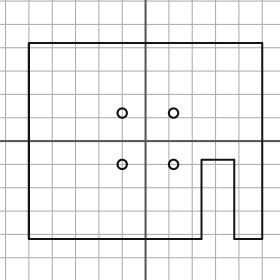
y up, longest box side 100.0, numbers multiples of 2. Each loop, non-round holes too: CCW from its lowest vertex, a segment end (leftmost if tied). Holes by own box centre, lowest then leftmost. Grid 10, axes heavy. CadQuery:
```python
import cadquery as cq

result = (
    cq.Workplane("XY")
    .moveTo(-50.0, -42.0)
    .lineTo(24.0, -42.0)
    .lineTo(24.0, -8.0)
    .lineTo(38.0, -8.0)
    .lineTo(38.0, -42.0)
    .lineTo(50.0, -42.0)
    .lineTo(50.0, 42.0)
    .lineTo(-50.0, 42.0)
    .close()
    .moveTo(-10.0, -10.0)
    .circle(2.0)
    .moveTo(12.0, -10.0)
    .circle(2.0)
    .moveTo(-10.0, 12.0)
    .circle(2.0)
    .moveTo(12.0, 12.0)
    .circle(2.0)
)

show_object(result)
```